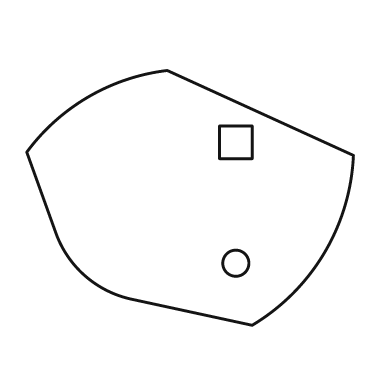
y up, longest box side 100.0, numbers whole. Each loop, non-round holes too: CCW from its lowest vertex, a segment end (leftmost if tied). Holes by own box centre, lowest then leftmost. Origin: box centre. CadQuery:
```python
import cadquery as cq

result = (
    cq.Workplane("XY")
    .moveTo(19.0, -39.0)
    .threePointArc((41.0, -17.0), (50.0, 13.0))
    .lineTo(-7.0, 39.0)
    .threePointArc((-31.0, 31.0), (-50.0, 14.0))
    .lineTo(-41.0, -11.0)
    .threePointArc((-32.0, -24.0), (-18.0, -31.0))
    .close()
    .moveTo(14.0, -20.0)
    .circle(4.0)
    .moveTo(9.0, 12.0)
    .lineTo(19.0, 12.0)
    .lineTo(19.0, 22.0)
    .lineTo(9.0, 22.0)
    .close()
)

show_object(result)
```